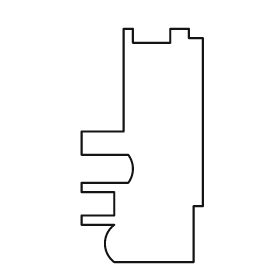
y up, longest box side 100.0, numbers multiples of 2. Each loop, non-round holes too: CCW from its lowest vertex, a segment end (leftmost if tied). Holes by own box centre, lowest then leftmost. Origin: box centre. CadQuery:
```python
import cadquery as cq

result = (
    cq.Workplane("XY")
    .moveTo(-12.0, -50.0)
    .lineTo(22.0, -50.0)
    .lineTo(22.0, -26.0)
    .lineTo(26.0, -26.0)
    .lineTo(26.0, 46.0)
    .lineTo(20.0, 46.0)
    .lineTo(20.0, 50.0)
    .lineTo(12.0, 50.0)
    .lineTo(12.0, 44.0)
    .lineTo(-4.0, 44.0)
    .lineTo(-4.0, 50.0)
    .lineTo(-8.0, 50.0)
    .lineTo(-8.0, 6.0)
    .lineTo(-26.0, 6.0)
    .lineTo(-26.0, -4.0)
    .lineTo(-6.0, -4.0)
    .threePointArc((-4.0, -10.0), (-6.0, -16.0))
    .lineTo(-26.0, -16.0)
    .lineTo(-26.0, -20.0)
    .lineTo(-12.0, -20.0)
    .lineTo(-12.0, -30.0)
    .lineTo(-26.0, -30.0)
    .lineTo(-26.0, -34.0)
    .lineTo(-12.0, -34.0)
    .threePointArc((-16.0, -42.0), (-12.0, -50.0))
    .close()
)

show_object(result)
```